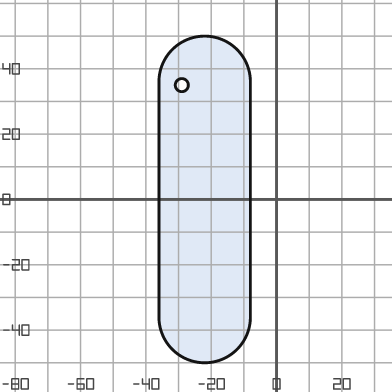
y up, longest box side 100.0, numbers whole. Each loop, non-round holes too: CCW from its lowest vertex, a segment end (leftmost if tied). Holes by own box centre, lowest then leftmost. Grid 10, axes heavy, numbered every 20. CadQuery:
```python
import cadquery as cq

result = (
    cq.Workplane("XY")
    .moveTo(-36.0, -36.0)
    .threePointArc((-22.0, -50.0), (-8.0, -36.0))
    .lineTo(-8.0, 36.0)
    .threePointArc((-22.0, 50.0), (-36.0, 36.0))
    .close()
    .moveTo(-29.0, 35.0)
    .circle(2.0)
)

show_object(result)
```